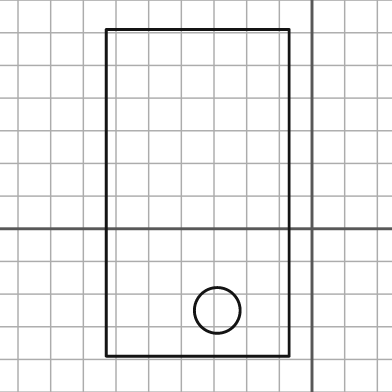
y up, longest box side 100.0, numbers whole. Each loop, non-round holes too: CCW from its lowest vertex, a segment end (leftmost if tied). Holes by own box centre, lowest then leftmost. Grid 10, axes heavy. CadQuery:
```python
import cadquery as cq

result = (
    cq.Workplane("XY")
    .moveTo(-63.0, -39.0)
    .lineTo(-7.0, -39.0)
    .lineTo(-7.0, 61.0)
    .lineTo(-63.0, 61.0)
    .close()
    .moveTo(-29.0, -25.0)
    .circle(7.0)
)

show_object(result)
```